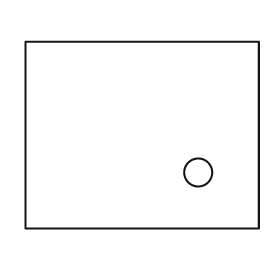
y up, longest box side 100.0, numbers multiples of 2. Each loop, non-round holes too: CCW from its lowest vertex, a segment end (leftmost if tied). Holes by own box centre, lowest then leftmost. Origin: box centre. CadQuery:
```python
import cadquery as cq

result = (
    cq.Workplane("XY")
    .moveTo(-50.0, -40.0)
    .lineTo(50.0, -40.0)
    .lineTo(50.0, 40.0)
    .lineTo(-50.0, 40.0)
    .close()
    .moveTo(24.0, -16.0)
    .circle(6.0)
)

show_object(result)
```